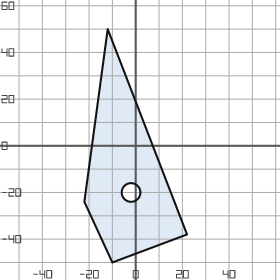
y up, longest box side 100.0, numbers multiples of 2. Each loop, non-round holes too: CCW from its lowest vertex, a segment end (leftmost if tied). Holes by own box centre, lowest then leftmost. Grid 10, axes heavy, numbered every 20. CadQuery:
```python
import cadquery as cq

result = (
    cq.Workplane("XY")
    .moveTo(-10.0, -50.0)
    .lineTo(22.0, -38.0)
    .lineTo(-12.0, 50.0)
    .lineTo(-22.0, -24.0)
    .close()
    .moveTo(-2.0, -20.0)
    .circle(4.0)
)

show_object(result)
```